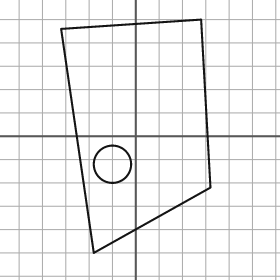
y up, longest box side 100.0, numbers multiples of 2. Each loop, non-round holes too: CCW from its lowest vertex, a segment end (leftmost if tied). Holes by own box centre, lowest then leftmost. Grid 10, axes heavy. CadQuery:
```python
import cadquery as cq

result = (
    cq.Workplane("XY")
    .moveTo(-18.0, -50.0)
    .lineTo(32.0, -22.0)
    .lineTo(28.0, 50.0)
    .lineTo(-32.0, 46.0)
    .close()
    .moveTo(-10.0, -12.0)
    .circle(8.0)
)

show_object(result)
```